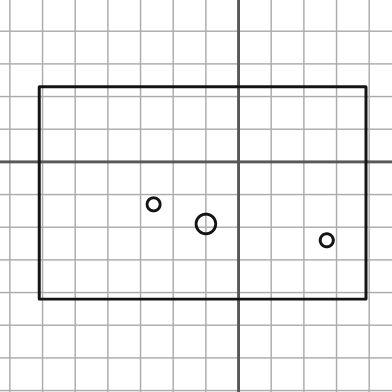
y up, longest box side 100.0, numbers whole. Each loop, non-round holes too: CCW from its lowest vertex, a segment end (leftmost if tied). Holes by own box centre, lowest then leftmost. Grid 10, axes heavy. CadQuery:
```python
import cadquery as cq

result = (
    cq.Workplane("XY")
    .moveTo(-61.0, -42.0)
    .lineTo(39.0, -42.0)
    .lineTo(39.0, 23.0)
    .lineTo(-61.0, 23.0)
    .close()
    .moveTo(27.0, -24.0)
    .circle(2.0)
    .moveTo(-10.0, -19.0)
    .circle(3.0)
    .moveTo(-26.0, -13.0)
    .circle(2.0)
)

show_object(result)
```